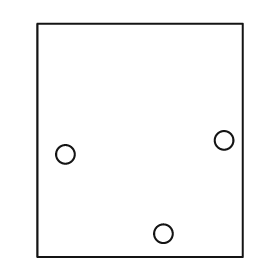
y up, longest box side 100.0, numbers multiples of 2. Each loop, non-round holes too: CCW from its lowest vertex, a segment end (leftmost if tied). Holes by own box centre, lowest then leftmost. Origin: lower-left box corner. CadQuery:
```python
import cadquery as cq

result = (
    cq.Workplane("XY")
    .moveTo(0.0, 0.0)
    .lineTo(88.0, 0.0)
    .lineTo(88.0, 100.0)
    .lineTo(0.0, 100.0)
    .close()
    .moveTo(54.0, 10.0)
    .circle(4.0)
    .moveTo(12.0, 44.0)
    .circle(4.0)
    .moveTo(80.0, 50.0)
    .circle(4.0)
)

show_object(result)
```